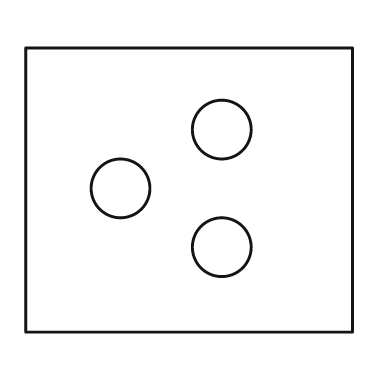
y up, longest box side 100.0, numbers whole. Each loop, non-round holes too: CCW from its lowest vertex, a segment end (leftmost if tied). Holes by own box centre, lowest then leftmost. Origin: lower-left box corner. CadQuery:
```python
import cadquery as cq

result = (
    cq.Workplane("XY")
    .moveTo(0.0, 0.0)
    .lineTo(100.0, 0.0)
    .lineTo(100.0, 87.0)
    .lineTo(0.0, 87.0)
    .close()
    .moveTo(60.0, 26.0)
    .circle(9.0)
    .moveTo(29.0, 44.0)
    .circle(9.0)
    .moveTo(60.0, 62.0)
    .circle(9.0)
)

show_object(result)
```